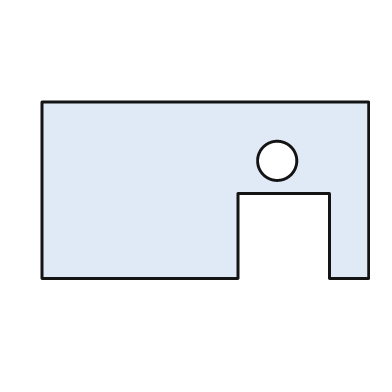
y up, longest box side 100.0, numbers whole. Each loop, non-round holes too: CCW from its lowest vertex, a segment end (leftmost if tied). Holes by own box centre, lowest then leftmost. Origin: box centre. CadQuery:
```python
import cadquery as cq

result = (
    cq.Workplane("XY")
    .moveTo(-50.0, -27.0)
    .lineTo(10.0, -27.0)
    .lineTo(10.0, -1.0)
    .lineTo(38.0, -1.0)
    .lineTo(38.0, -27.0)
    .lineTo(50.0, -27.0)
    .lineTo(50.0, 27.0)
    .lineTo(-50.0, 27.0)
    .close()
    .moveTo(22.0, 9.0)
    .circle(6.0)
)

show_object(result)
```